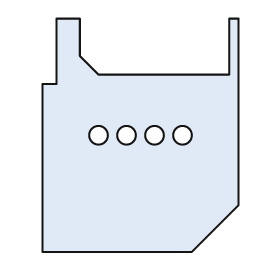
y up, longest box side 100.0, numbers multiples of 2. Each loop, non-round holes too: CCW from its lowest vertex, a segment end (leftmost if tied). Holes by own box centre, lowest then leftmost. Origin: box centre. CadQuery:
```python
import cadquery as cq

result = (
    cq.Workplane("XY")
    .moveTo(-42.0, -50.0)
    .lineTo(22.0, -50.0)
    .lineTo(42.0, -30.0)
    .lineTo(42.0, 50.0)
    .lineTo(38.0, 50.0)
    .lineTo(38.0, 26.0)
    .lineTo(-18.0, 26.0)
    .lineTo(-26.0, 34.0)
    .lineTo(-26.0, 50.0)
    .lineTo(-36.0, 50.0)
    .lineTo(-36.0, 22.0)
    .lineTo(-42.0, 22.0)
    .close()
    .moveTo(-18.0, 0.0)
    .circle(4.0)
    .moveTo(-6.0, 0.0)
    .circle(4.0)
    .moveTo(6.0, 0.0)
    .circle(4.0)
    .moveTo(18.0, 0.0)
    .circle(4.0)
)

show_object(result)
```